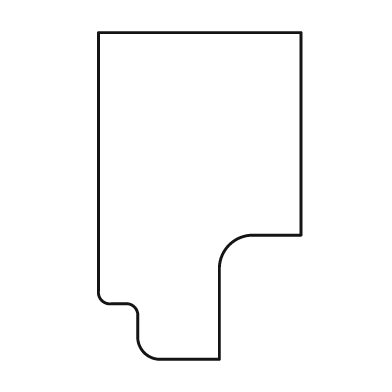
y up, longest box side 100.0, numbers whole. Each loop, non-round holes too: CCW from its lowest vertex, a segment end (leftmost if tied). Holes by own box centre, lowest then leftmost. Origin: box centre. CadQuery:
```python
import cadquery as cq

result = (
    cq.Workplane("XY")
    .moveTo(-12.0, -50.0)
    .lineTo(6.0, -50.0)
    .lineTo(6.0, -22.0)
    .threePointArc((9.0, -15.0), (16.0, -12.0))
    .lineTo(31.0, -12.0)
    .lineTo(31.0, 50.0)
    .lineTo(-31.0, 50.0)
    .lineTo(-31.0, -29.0)
    .threePointArc((-30.0, -32.0), (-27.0, -33.0))
    .lineTo(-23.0, -33.0)
    .threePointArc((-20.0, -34.0), (-19.0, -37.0))
    .lineTo(-19.0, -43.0)
    .threePointArc((-17.0, -48.0), (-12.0, -50.0))
    .close()
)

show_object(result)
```